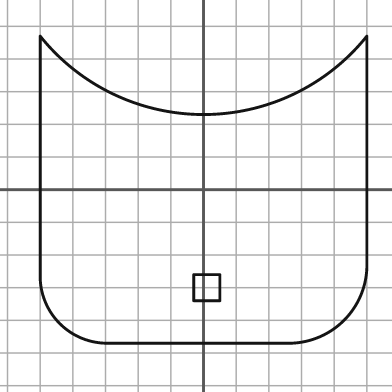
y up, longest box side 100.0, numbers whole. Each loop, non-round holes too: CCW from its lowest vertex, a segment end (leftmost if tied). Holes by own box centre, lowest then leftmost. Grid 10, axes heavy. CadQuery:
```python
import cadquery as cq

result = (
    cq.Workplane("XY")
    .moveTo(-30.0, -47.0)
    .lineTo(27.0, -47.0)
    .threePointArc((43.0, -40.0), (50.0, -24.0))
    .lineTo(50.0, 47.0)
    .threePointArc((0.0, 23.0), (-50.0, 47.0))
    .lineTo(-50.0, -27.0)
    .threePointArc((-44.0, -41.0), (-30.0, -47.0))
    .close()
    .moveTo(-3.0, -34.0)
    .lineTo(5.0, -34.0)
    .lineTo(5.0, -26.0)
    .lineTo(-3.0, -26.0)
    .close()
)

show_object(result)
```